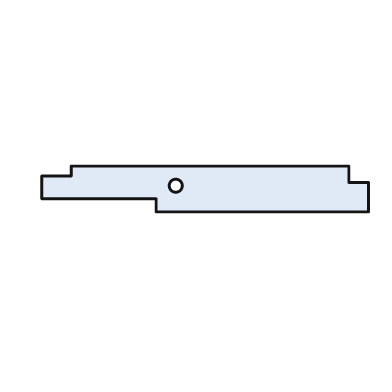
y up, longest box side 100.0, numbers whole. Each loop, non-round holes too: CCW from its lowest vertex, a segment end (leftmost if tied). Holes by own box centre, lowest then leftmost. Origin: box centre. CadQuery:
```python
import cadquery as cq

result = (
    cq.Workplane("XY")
    .moveTo(-15.0, -7.0)
    .lineTo(50.0, -7.0)
    .lineTo(50.0, 2.0)
    .lineTo(44.0, 2.0)
    .lineTo(44.0, 7.0)
    .lineTo(-41.0, 7.0)
    .lineTo(-41.0, 4.0)
    .lineTo(-50.0, 4.0)
    .lineTo(-50.0, -3.0)
    .lineTo(-15.0, -3.0)
    .close()
    .moveTo(-9.0, 1.0)
    .circle(2.0)
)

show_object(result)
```